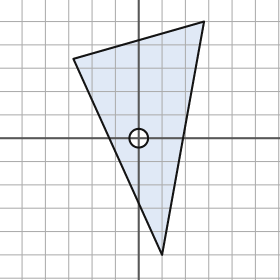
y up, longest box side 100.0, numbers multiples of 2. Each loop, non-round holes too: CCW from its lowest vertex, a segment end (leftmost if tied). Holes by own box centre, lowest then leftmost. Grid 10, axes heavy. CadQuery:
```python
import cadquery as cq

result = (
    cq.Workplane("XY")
    .moveTo(10.0, -50.0)
    .lineTo(28.0, 50.0)
    .lineTo(-28.0, 34.0)
    .close()
    .moveTo(0.0, 0.0)
    .circle(4.0)
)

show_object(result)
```